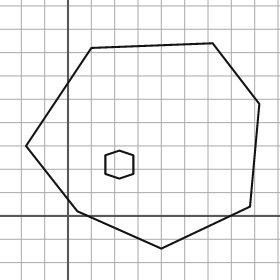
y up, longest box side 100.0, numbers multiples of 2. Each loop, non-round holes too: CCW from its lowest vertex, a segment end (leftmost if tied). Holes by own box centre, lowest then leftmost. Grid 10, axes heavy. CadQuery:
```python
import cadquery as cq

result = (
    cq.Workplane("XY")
    .moveTo(40.0, -14.0)
    .lineTo(78.0, 4.0)
    .lineTo(82.0, 48.0)
    .lineTo(62.0, 74.0)
    .lineTo(10.0, 72.0)
    .lineTo(-18.0, 30.0)
    .lineTo(4.0, 2.0)
    .close()
    .moveTo(22.0, 16.0)
    .lineTo(28.0, 18.0)
    .lineTo(28.0, 26.0)
    .lineTo(22.0, 28.0)
    .lineTo(16.0, 26.0)
    .lineTo(16.0, 18.0)
    .close()
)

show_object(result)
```